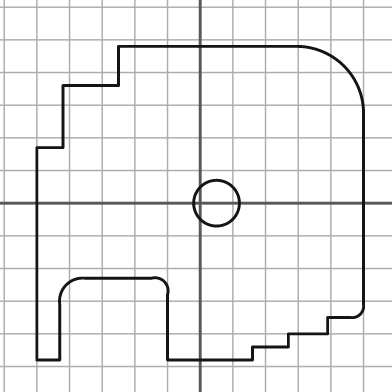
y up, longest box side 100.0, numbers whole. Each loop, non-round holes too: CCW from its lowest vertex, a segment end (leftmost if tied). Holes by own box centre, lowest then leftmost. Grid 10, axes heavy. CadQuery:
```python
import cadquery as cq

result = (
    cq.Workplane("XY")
    .moveTo(-50.0, -48.0)
    .lineTo(-43.0, -48.0)
    .lineTo(-43.0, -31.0)
    .threePointArc((-41.0, -25.0), (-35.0, -23.0))
    .lineTo(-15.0, -23.0)
    .threePointArc((-11.0, -24.0), (-10.0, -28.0))
    .lineTo(-10.0, -48.0)
    .lineTo(16.0, -48.0)
    .lineTo(16.0, -44.0)
    .lineTo(27.0, -44.0)
    .lineTo(27.0, -40.0)
    .lineTo(39.0, -40.0)
    .lineTo(39.0, -35.0)
    .lineTo(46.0, -35.0)
    .threePointArc((49.0, -34.0), (50.0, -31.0))
    .lineTo(50.0, 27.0)
    .threePointArc((44.0, 42.0), (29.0, 48.0))
    .lineTo(-25.0, 48.0)
    .lineTo(-25.0, 36.0)
    .lineTo(-42.0, 36.0)
    .lineTo(-42.0, 17.0)
    .lineTo(-50.0, 17.0)
    .close()
    .moveTo(5.0, 0.0)
    .circle(7.0)
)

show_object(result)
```